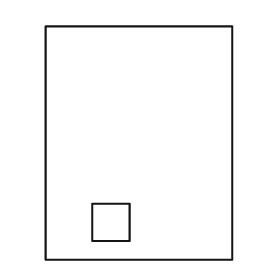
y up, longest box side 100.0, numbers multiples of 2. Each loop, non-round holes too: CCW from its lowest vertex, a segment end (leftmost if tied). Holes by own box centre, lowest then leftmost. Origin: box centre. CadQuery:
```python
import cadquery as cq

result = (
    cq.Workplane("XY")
    .moveTo(-40.0, -50.0)
    .lineTo(40.0, -50.0)
    .lineTo(40.0, 50.0)
    .lineTo(-40.0, 50.0)
    .close()
    .moveTo(-20.0, -42.0)
    .lineTo(-4.0, -42.0)
    .lineTo(-4.0, -26.0)
    .lineTo(-20.0, -26.0)
    .close()
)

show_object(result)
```